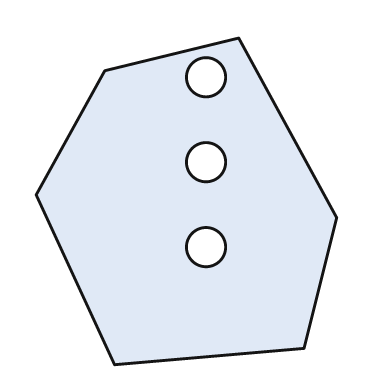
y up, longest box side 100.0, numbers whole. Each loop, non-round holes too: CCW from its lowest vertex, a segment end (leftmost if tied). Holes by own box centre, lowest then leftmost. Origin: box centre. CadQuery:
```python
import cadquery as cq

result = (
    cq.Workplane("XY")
    .moveTo(-22.0, -50.0)
    .lineTo(36.0, -45.0)
    .lineTo(46.0, -5.0)
    .lineTo(16.0, 50.0)
    .lineTo(-25.0, 40.0)
    .lineTo(-46.0, 2.0)
    .close()
    .moveTo(6.0, -14.0)
    .circle(6.0)
    .moveTo(6.0, 12.0)
    .circle(6.0)
    .moveTo(6.0, 38.0)
    .circle(6.0)
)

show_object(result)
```